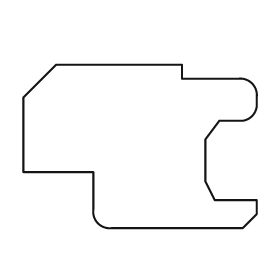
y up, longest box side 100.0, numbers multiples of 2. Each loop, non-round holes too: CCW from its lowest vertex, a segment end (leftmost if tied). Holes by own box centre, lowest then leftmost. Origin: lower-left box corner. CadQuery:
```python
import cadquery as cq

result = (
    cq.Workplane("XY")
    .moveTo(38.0, 0.0)
    .lineTo(94.0, 0.0)
    .lineTo(100.0, 6.0)
    .lineTo(100.0, 12.0)
    .lineTo(82.0, 12.0)
    .lineTo(78.0, 20.0)
    .lineTo(78.0, 38.0)
    .lineTo(84.0, 46.0)
    .lineTo(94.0, 46.0)
    .threePointArc((98.0, 48.0), (100.0, 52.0))
    .lineTo(100.0, 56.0)
    .threePointArc((98.0, 62.0), (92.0, 64.0))
    .lineTo(68.0, 64.0)
    .lineTo(68.0, 70.0)
    .lineTo(14.0, 70.0)
    .lineTo(0.0, 56.0)
    .lineTo(0.0, 24.0)
    .lineTo(30.0, 24.0)
    .lineTo(30.0, 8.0)
    .threePointArc((32.0, 2.0), (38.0, 0.0))
    .close()
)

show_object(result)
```